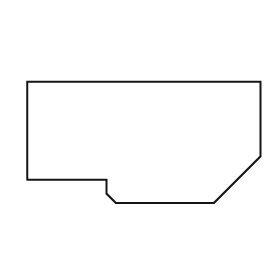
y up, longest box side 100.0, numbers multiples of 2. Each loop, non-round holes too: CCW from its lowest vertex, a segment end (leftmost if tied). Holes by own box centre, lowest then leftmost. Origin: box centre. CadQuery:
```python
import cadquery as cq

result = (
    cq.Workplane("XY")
    .moveTo(-12.0, -26.0)
    .lineTo(30.0, -26.0)
    .lineTo(50.0, -6.0)
    .lineTo(50.0, 26.0)
    .lineTo(-50.0, 26.0)
    .lineTo(-50.0, -16.0)
    .lineTo(-16.0, -16.0)
    .lineTo(-16.0, -22.0)
    .close()
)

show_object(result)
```